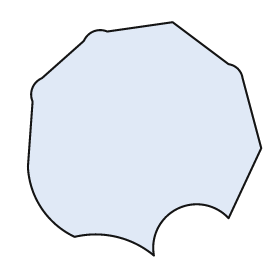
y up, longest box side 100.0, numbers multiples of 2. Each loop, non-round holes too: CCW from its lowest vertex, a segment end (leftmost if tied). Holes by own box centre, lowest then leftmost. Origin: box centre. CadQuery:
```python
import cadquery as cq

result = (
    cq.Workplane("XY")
    .moveTo(4.0, -50.0)
    .threePointArc((14.0, -30.0), (36.0, -34.0))
    .lineTo(50.0, -4.0)
    .lineTo(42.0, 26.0)
    .threePointArc((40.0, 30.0), (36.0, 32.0))
    .lineTo(12.0, 50.0)
    .lineTo(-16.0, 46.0)
    .threePointArc((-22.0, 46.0), (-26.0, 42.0))
    .lineTo(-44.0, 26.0)
    .threePointArc((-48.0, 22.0), (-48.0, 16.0))
    .lineTo(-50.0, -12.0)
    .threePointArc((-44.0, -30.0), (-30.0, -42.0))
    .threePointArc((-12.0, -42.0), (4.0, -50.0))
    .close()
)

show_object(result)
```